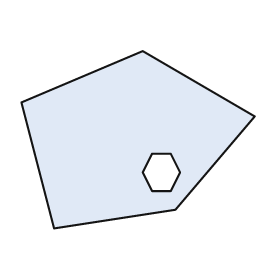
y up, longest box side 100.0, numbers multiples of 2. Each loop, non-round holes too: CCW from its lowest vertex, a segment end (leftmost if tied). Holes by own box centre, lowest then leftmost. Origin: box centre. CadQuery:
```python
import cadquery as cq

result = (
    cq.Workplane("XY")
    .moveTo(-36.0, -38.0)
    .lineTo(16.0, -30.0)
    .lineTo(50.0, 10.0)
    .lineTo(2.0, 38.0)
    .lineTo(-50.0, 16.0)
    .close()
    .moveTo(6.0, -22.0)
    .lineTo(14.0, -22.0)
    .lineTo(18.0, -14.0)
    .lineTo(14.0, -6.0)
    .lineTo(6.0, -6.0)
    .lineTo(2.0, -14.0)
    .close()
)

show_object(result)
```